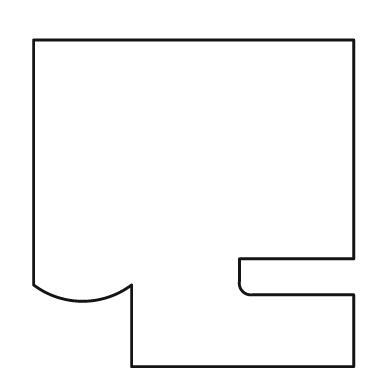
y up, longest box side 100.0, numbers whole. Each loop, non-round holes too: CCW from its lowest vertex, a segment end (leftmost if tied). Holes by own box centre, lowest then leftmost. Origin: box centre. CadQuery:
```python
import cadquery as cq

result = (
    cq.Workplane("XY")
    .moveTo(-19.0, -50.0)
    .lineTo(49.0, -50.0)
    .lineTo(49.0, -28.0)
    .lineTo(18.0, -28.0)
    .threePointArc((15.0, -27.0), (14.0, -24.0))
    .lineTo(14.0, -17.0)
    .lineTo(49.0, -17.0)
    .lineTo(49.0, 50.0)
    .lineTo(-49.0, 50.0)
    .lineTo(-49.0, -25.0)
    .threePointArc((-34.0, -30.0), (-19.0, -25.0))
    .close()
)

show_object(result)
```